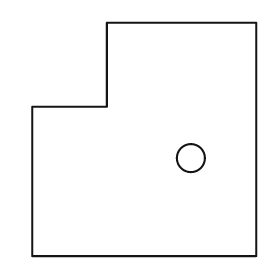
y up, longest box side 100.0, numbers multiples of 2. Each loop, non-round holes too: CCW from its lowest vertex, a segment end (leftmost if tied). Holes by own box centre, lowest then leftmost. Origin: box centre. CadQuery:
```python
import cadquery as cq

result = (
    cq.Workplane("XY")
    .moveTo(-48.0, -50.0)
    .lineTo(48.0, -50.0)
    .lineTo(48.0, 50.0)
    .lineTo(-16.0, 50.0)
    .lineTo(-16.0, 14.0)
    .lineTo(-48.0, 14.0)
    .close()
    .moveTo(20.0, -8.0)
    .circle(6.0)
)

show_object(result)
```